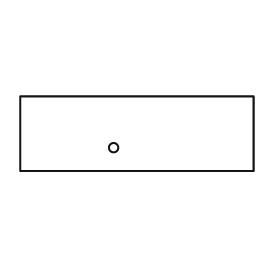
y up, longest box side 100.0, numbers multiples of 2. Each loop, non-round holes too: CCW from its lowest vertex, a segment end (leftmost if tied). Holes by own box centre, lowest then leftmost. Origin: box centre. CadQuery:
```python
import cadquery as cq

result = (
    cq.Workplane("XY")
    .moveTo(-50.0, -16.0)
    .lineTo(50.0, -16.0)
    .lineTo(50.0, 16.0)
    .lineTo(-50.0, 16.0)
    .close()
    .moveTo(-10.0, -6.0)
    .circle(2.0)
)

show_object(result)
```